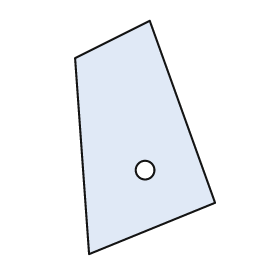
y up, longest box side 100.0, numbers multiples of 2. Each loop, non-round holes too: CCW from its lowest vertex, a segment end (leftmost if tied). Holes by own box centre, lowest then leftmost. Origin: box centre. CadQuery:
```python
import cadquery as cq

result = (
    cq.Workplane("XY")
    .moveTo(-24.0, -50.0)
    .lineTo(30.0, -28.0)
    .lineTo(2.0, 50.0)
    .lineTo(-30.0, 34.0)
    .close()
    .moveTo(0.0, -14.0)
    .circle(4.0)
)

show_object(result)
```